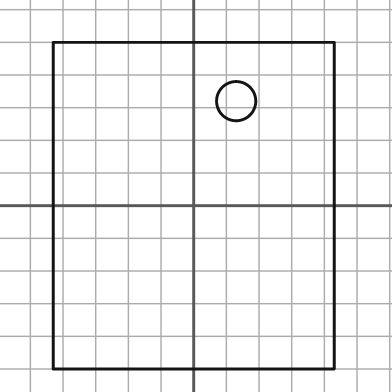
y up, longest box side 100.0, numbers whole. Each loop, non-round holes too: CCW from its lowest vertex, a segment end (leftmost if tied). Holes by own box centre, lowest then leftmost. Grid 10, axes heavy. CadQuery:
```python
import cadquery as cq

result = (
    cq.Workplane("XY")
    .moveTo(-43.0, -50.0)
    .lineTo(43.0, -50.0)
    .lineTo(43.0, 50.0)
    .lineTo(-43.0, 50.0)
    .close()
    .moveTo(13.0, 32.0)
    .circle(6.0)
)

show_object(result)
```